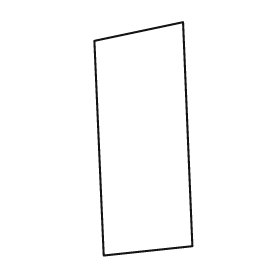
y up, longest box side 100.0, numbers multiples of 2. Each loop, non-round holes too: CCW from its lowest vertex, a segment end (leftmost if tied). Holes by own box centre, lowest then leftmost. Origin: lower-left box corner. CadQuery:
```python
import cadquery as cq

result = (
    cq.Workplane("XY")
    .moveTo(4.0, 0.0)
    .lineTo(42.0, 4.0)
    .lineTo(38.0, 100.0)
    .lineTo(0.0, 92.0)
    .close()
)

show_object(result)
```